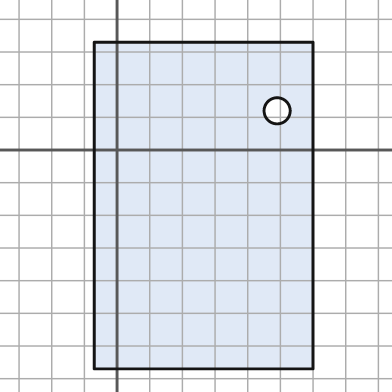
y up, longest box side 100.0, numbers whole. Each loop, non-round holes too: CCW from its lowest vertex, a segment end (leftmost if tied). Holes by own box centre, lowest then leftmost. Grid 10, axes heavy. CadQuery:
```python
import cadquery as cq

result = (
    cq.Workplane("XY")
    .moveTo(-7.0, -67.0)
    .lineTo(60.0, -67.0)
    .lineTo(60.0, 33.0)
    .lineTo(-7.0, 33.0)
    .close()
    .moveTo(49.0, 12.0)
    .circle(4.0)
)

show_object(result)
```